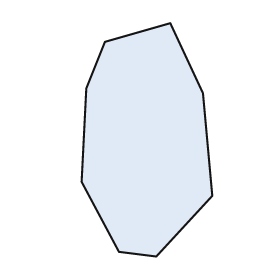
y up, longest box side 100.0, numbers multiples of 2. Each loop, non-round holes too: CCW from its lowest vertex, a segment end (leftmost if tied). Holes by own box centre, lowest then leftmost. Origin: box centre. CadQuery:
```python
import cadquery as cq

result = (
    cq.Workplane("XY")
    .moveTo(4.0, -50.0)
    .lineTo(28.0, -24.0)
    .lineTo(24.0, 20.0)
    .lineTo(10.0, 50.0)
    .lineTo(-18.0, 42.0)
    .lineTo(-26.0, 22.0)
    .lineTo(-28.0, -18.0)
    .lineTo(-12.0, -48.0)
    .close()
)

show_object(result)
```